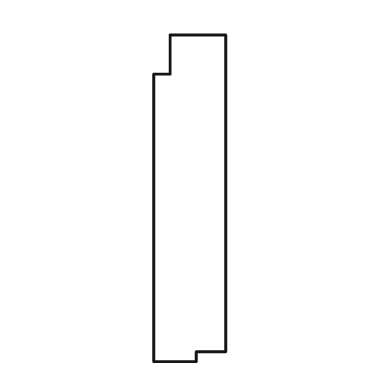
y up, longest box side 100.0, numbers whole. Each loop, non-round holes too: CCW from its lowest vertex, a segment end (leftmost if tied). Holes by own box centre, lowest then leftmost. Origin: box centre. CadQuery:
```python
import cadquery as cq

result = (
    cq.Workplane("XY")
    .moveTo(-11.0, -50.0)
    .lineTo(2.0, -50.0)
    .lineTo(2.0, -47.0)
    .lineTo(11.0, -47.0)
    .lineTo(11.0, 50.0)
    .lineTo(-6.0, 50.0)
    .lineTo(-6.0, 38.0)
    .lineTo(-11.0, 38.0)
    .close()
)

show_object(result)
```